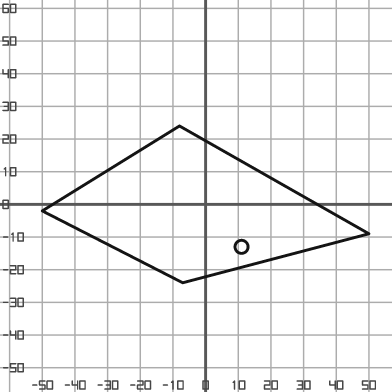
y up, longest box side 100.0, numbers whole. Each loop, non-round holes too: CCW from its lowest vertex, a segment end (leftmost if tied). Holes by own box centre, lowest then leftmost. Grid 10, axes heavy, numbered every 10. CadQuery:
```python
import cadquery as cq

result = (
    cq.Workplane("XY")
    .moveTo(-7.0, -24.0)
    .lineTo(50.0, -9.0)
    .lineTo(-8.0, 24.0)
    .lineTo(-50.0, -2.0)
    .close()
    .moveTo(11.0, -13.0)
    .circle(2.0)
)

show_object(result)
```